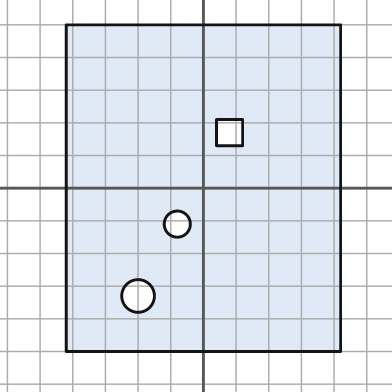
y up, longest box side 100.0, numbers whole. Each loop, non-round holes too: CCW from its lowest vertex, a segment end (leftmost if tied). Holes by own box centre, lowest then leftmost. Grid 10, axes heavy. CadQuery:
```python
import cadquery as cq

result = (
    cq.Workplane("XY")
    .moveTo(-42.0, -50.0)
    .lineTo(42.0, -50.0)
    .lineTo(42.0, 50.0)
    .lineTo(-42.0, 50.0)
    .close()
    .moveTo(-20.0, -33.0)
    .circle(5.0)
    .moveTo(-8.0, -11.0)
    .circle(4.0)
    .moveTo(4.0, 13.0)
    .lineTo(12.0, 13.0)
    .lineTo(12.0, 21.0)
    .lineTo(4.0, 21.0)
    .close()
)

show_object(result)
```